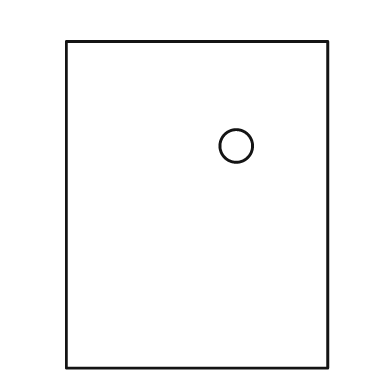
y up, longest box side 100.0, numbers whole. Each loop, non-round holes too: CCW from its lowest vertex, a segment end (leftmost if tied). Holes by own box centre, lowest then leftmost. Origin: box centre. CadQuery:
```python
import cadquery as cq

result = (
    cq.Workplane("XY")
    .moveTo(-40.0, -50.0)
    .lineTo(40.0, -50.0)
    .lineTo(40.0, 50.0)
    .lineTo(-40.0, 50.0)
    .close()
    .moveTo(12.0, 18.0)
    .circle(5.0)
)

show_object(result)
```